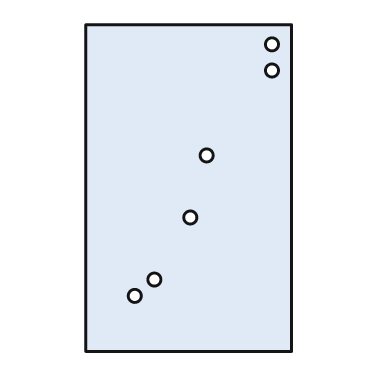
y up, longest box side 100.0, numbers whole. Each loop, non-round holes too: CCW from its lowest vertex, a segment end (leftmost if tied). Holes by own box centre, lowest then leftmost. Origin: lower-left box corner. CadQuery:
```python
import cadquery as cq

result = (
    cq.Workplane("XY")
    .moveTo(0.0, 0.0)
    .lineTo(63.0, 0.0)
    .lineTo(63.0, 100.0)
    .lineTo(0.0, 100.0)
    .close()
    .moveTo(15.0, 17.0)
    .circle(2.0)
    .moveTo(21.0, 22.0)
    .circle(2.0)
    .moveTo(32.0, 41.0)
    .circle(2.0)
    .moveTo(37.0, 60.0)
    .circle(2.0)
    .moveTo(57.0, 86.0)
    .circle(2.0)
    .moveTo(57.0, 94.0)
    .circle(2.0)
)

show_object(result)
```